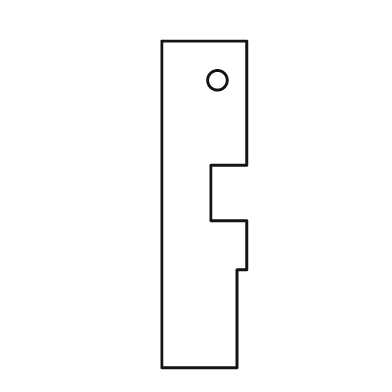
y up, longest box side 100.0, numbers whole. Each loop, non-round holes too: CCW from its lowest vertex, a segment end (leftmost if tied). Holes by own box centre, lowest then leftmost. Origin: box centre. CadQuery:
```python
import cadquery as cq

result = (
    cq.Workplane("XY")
    .moveTo(-13.0, -50.0)
    .lineTo(10.0, -50.0)
    .lineTo(10.0, -20.0)
    .lineTo(13.0, -20.0)
    .lineTo(13.0, -5.0)
    .lineTo(2.0, -5.0)
    .lineTo(2.0, 12.0)
    .lineTo(13.0, 12.0)
    .lineTo(13.0, 50.0)
    .lineTo(-13.0, 50.0)
    .close()
    .moveTo(4.0, 38.0)
    .circle(3.0)
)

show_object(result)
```